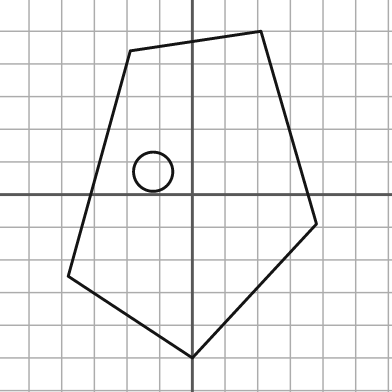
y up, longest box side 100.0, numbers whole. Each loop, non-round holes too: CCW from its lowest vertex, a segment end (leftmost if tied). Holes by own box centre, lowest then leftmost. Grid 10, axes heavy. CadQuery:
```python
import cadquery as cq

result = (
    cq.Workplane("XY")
    .moveTo(0.0, -50.0)
    .lineTo(38.0, -9.0)
    .lineTo(21.0, 50.0)
    .lineTo(-19.0, 44.0)
    .lineTo(-38.0, -25.0)
    .close()
    .moveTo(-12.0, 7.0)
    .circle(6.0)
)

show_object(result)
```